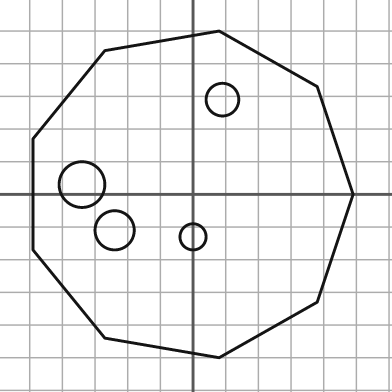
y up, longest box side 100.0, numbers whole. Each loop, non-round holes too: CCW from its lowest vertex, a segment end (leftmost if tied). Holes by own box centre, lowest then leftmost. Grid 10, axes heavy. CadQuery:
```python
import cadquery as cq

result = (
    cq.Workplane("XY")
    .moveTo(8.0, -50.0)
    .lineTo(38.0, -33.0)
    .lineTo(49.0, 0.0)
    .lineTo(38.0, 33.0)
    .lineTo(8.0, 50.0)
    .lineTo(-27.0, 44.0)
    .lineTo(-49.0, 17.0)
    .lineTo(-49.0, -17.0)
    .lineTo(-27.0, -44.0)
    .close()
    .moveTo(0.0, -13.0)
    .circle(4.0)
    .moveTo(-24.0, -11.0)
    .circle(6.0)
    .moveTo(-34.0, 3.0)
    .circle(7.0)
    .moveTo(9.0, 29.0)
    .circle(5.0)
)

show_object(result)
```